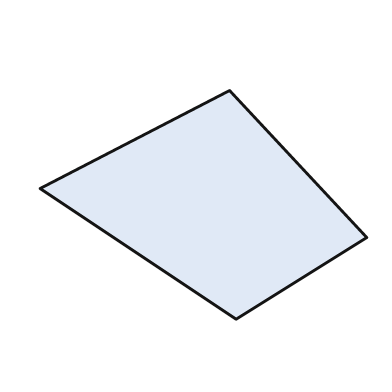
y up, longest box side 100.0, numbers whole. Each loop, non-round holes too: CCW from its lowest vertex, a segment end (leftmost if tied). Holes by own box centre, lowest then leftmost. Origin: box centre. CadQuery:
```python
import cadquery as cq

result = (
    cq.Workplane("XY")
    .moveTo(10.0, -35.0)
    .lineTo(50.0, -10.0)
    .lineTo(8.0, 35.0)
    .lineTo(-50.0, 5.0)
    .close()
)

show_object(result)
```